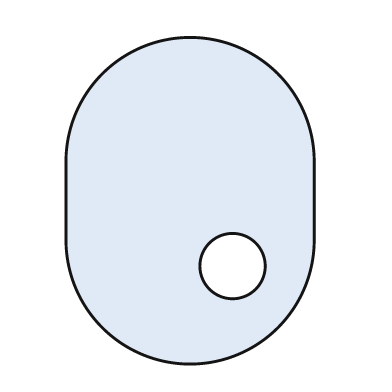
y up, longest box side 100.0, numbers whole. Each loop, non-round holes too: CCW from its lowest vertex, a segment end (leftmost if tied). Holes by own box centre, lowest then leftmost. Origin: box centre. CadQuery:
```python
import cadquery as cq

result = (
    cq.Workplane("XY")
    .moveTo(-38.0, -12.0)
    .threePointArc((0.0, -50.0), (38.0, -12.0))
    .lineTo(38.0, 12.0)
    .threePointArc((0.0, 50.0), (-38.0, 12.0))
    .close()
    .moveTo(13.0, -20.0)
    .circle(10.0)
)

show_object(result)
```